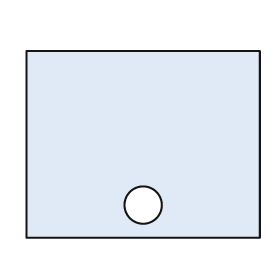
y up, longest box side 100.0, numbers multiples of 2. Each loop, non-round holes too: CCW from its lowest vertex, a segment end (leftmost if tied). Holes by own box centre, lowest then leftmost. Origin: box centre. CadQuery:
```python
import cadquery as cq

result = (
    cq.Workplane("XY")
    .moveTo(-50.0, -40.0)
    .lineTo(50.0, -40.0)
    .lineTo(50.0, 40.0)
    .lineTo(-50.0, 40.0)
    .close()
    .moveTo(0.0, -26.0)
    .circle(8.0)
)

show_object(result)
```